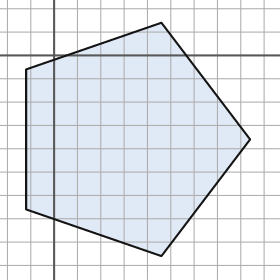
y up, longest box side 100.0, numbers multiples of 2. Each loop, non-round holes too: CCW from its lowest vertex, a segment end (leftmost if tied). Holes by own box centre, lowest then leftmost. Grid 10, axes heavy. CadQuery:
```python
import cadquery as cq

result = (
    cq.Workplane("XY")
    .moveTo(46.0, -86.0)
    .lineTo(84.0, -36.0)
    .lineTo(46.0, 14.0)
    .lineTo(-12.0, -6.0)
    .lineTo(-12.0, -66.0)
    .close()
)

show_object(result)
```